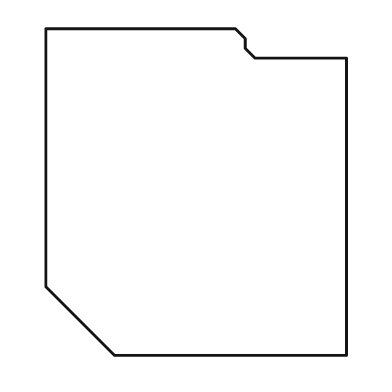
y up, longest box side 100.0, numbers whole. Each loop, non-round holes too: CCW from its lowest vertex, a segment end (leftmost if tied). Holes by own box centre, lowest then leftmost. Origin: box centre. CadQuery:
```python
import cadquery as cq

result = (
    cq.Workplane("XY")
    .moveTo(-25.0, -50.0)
    .lineTo(46.0, -50.0)
    .lineTo(46.0, 41.0)
    .lineTo(18.0, 41.0)
    .lineTo(15.0, 44.0)
    .lineTo(15.0, 47.0)
    .lineTo(12.0, 50.0)
    .lineTo(-46.0, 50.0)
    .lineTo(-46.0, -29.0)
    .close()
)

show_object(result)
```